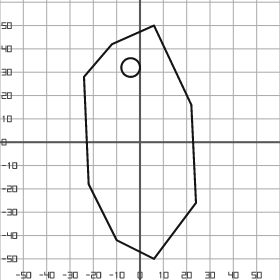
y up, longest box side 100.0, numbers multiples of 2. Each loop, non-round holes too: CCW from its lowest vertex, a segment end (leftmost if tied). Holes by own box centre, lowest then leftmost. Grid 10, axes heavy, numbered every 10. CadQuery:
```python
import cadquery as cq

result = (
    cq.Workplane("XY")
    .moveTo(6.0, -50.0)
    .lineTo(24.0, -26.0)
    .lineTo(22.0, 16.0)
    .lineTo(6.0, 50.0)
    .lineTo(-12.0, 42.0)
    .lineTo(-24.0, 28.0)
    .lineTo(-22.0, -18.0)
    .lineTo(-10.0, -42.0)
    .close()
    .moveTo(-4.0, 32.0)
    .circle(4.0)
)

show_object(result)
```